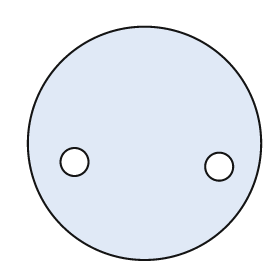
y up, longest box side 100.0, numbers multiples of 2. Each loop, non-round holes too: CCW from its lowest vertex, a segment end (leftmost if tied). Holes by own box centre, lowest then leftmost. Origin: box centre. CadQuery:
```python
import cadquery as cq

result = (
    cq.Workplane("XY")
    .moveTo(0.0, 0.0)
    .circle(50.0)
    .moveTo(32.0, -10.0)
    .circle(6.0)
    .moveTo(-30.0, -8.0)
    .circle(6.0)
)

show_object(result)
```